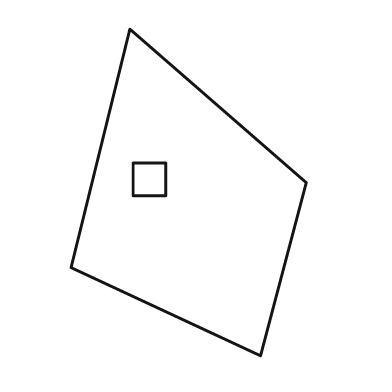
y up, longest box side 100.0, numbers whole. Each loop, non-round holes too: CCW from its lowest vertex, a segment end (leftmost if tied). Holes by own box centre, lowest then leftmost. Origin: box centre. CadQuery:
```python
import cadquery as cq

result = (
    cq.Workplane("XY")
    .moveTo(22.0, -50.0)
    .lineTo(36.0, 3.0)
    .lineTo(-18.0, 50.0)
    .lineTo(-36.0, -23.0)
    .close()
    .moveTo(-17.0, -1.0)
    .lineTo(-7.0, -1.0)
    .lineTo(-7.0, 9.0)
    .lineTo(-17.0, 9.0)
    .close()
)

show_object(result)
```